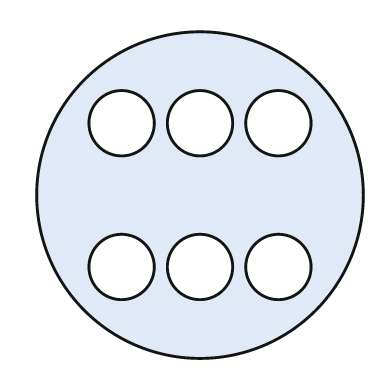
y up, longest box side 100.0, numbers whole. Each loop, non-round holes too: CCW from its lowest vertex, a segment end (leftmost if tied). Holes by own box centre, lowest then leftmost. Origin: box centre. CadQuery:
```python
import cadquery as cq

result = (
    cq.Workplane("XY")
    .moveTo(0.0, 0.0)
    .circle(50.0)
    .moveTo(-24.0, -22.0)
    .circle(10.0)
    .moveTo(0.0, -22.0)
    .circle(10.0)
    .moveTo(24.0, -22.0)
    .circle(10.0)
    .moveTo(-24.0, 22.0)
    .circle(10.0)
    .moveTo(0.0, 22.0)
    .circle(10.0)
    .moveTo(24.0, 22.0)
    .circle(10.0)
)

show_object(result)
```